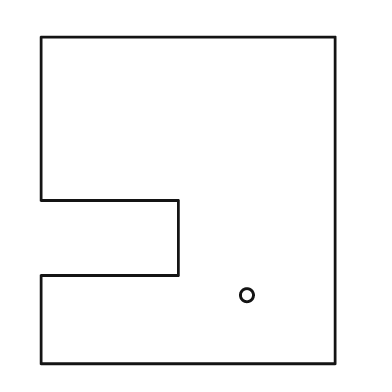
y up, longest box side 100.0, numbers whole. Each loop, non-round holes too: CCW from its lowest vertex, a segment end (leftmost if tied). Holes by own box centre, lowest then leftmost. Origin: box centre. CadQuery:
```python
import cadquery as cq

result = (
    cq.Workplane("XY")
    .moveTo(-45.0, -50.0)
    .lineTo(45.0, -50.0)
    .lineTo(45.0, 50.0)
    .lineTo(-45.0, 50.0)
    .lineTo(-45.0, 0.0)
    .lineTo(-3.0, 0.0)
    .lineTo(-3.0, -23.0)
    .lineTo(-45.0, -23.0)
    .close()
    .moveTo(18.0, -29.0)
    .circle(2.0)
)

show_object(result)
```